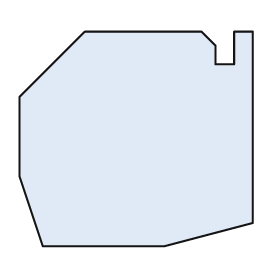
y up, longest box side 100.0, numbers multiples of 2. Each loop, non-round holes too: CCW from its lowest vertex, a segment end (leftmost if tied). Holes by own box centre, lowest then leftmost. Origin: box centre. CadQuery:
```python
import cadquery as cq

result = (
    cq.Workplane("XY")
    .moveTo(-40.0, -46.0)
    .lineTo(12.0, -46.0)
    .lineTo(50.0, -36.0)
    .lineTo(50.0, 46.0)
    .lineTo(42.0, 46.0)
    .lineTo(42.0, 32.0)
    .lineTo(34.0, 32.0)
    .lineTo(34.0, 40.0)
    .lineTo(28.0, 46.0)
    .lineTo(-22.0, 46.0)
    .lineTo(-50.0, 18.0)
    .lineTo(-50.0, -16.0)
    .close()
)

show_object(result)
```